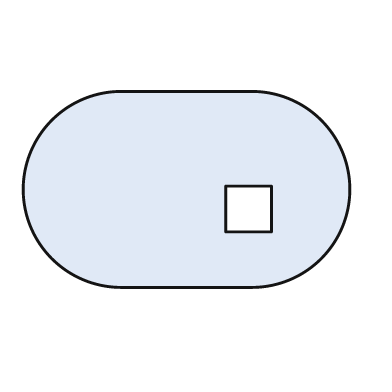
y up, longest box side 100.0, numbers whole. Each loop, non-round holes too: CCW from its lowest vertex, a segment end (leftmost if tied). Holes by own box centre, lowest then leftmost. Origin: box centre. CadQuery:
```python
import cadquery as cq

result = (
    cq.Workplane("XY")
    .moveTo(-20.0, -30.0)
    .lineTo(20.0, -30.0)
    .threePointArc((50.0, 0.0), (20.0, 30.0))
    .lineTo(-20.0, 30.0)
    .threePointArc((-50.0, 0.0), (-20.0, -30.0))
    .close()
    .moveTo(12.0, -13.0)
    .lineTo(26.0, -13.0)
    .lineTo(26.0, 1.0)
    .lineTo(12.0, 1.0)
    .close()
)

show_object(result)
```